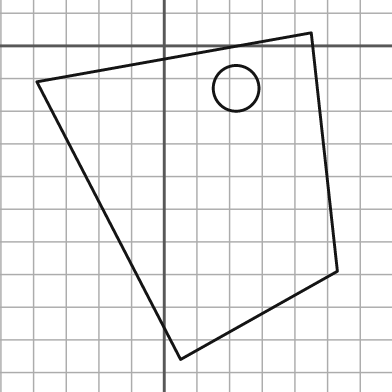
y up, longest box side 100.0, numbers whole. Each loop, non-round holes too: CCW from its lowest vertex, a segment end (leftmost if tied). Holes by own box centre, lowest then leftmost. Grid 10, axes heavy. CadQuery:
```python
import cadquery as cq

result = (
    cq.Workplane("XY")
    .moveTo(5.0, -96.0)
    .lineTo(53.0, -69.0)
    .lineTo(45.0, 4.0)
    .lineTo(-39.0, -11.0)
    .close()
    .moveTo(22.0, -13.0)
    .circle(7.0)
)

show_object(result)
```